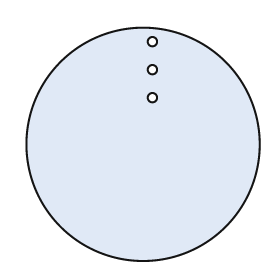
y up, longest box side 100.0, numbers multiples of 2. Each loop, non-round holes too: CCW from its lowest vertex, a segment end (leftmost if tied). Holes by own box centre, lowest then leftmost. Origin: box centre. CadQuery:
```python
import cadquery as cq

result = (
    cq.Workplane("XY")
    .moveTo(0.0, 0.0)
    .circle(50.0)
    .moveTo(4.0, 20.0)
    .circle(2.0)
    .moveTo(4.0, 32.0)
    .circle(2.0)
    .moveTo(4.0, 44.0)
    .circle(2.0)
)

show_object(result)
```